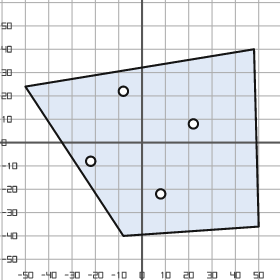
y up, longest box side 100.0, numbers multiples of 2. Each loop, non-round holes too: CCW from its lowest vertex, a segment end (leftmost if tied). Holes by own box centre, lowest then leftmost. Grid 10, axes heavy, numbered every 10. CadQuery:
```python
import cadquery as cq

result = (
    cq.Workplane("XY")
    .moveTo(-8.0, -40.0)
    .lineTo(50.0, -36.0)
    .lineTo(48.0, 40.0)
    .lineTo(-50.0, 24.0)
    .close()
    .moveTo(8.0, -22.0)
    .circle(2.0)
    .moveTo(-22.0, -8.0)
    .circle(2.0)
    .moveTo(22.0, 8.0)
    .circle(2.0)
    .moveTo(-8.0, 22.0)
    .circle(2.0)
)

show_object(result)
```